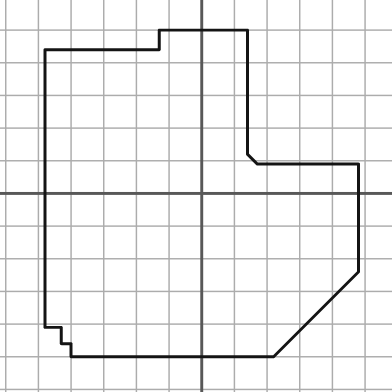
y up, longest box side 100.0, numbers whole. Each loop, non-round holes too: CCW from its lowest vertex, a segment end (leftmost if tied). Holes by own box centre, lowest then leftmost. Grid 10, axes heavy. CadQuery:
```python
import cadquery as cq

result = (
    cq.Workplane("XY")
    .moveTo(-40.0, -50.0)
    .lineTo(22.0, -50.0)
    .lineTo(48.0, -24.0)
    .lineTo(48.0, 9.0)
    .lineTo(17.0, 9.0)
    .lineTo(14.0, 12.0)
    .lineTo(14.0, 50.0)
    .lineTo(-13.0, 50.0)
    .lineTo(-13.0, 44.0)
    .lineTo(-48.0, 44.0)
    .lineTo(-48.0, -41.0)
    .lineTo(-43.0, -41.0)
    .lineTo(-43.0, -46.0)
    .lineTo(-40.0, -46.0)
    .close()
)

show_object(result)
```